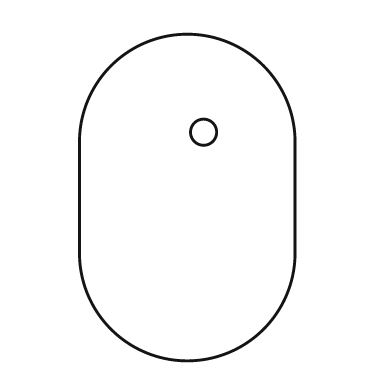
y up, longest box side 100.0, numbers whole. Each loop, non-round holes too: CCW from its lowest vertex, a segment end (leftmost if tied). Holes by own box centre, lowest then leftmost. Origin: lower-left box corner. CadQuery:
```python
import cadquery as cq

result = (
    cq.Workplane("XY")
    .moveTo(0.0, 33.0)
    .threePointArc((33.0, 0.0), (66.0, 33.0))
    .lineTo(66.0, 67.0)
    .threePointArc((33.0, 100.0), (0.0, 67.0))
    .close()
    .moveTo(38.0, 70.0)
    .circle(4.0)
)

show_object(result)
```